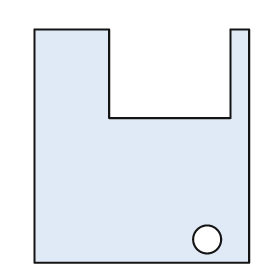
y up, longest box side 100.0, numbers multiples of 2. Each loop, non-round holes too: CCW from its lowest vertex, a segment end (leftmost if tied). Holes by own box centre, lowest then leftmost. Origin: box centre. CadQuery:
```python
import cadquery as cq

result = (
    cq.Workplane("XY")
    .moveTo(-46.0, -50.0)
    .lineTo(46.0, -50.0)
    .lineTo(46.0, 50.0)
    .lineTo(38.0, 50.0)
    .lineTo(38.0, 12.0)
    .lineTo(-14.0, 12.0)
    .lineTo(-14.0, 50.0)
    .lineTo(-46.0, 50.0)
    .close()
    .moveTo(28.0, -40.0)
    .circle(6.0)
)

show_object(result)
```